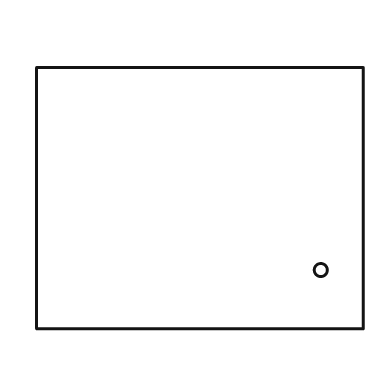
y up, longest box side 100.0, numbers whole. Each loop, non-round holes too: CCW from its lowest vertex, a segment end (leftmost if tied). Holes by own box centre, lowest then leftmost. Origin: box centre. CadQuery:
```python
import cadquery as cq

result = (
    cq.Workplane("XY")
    .moveTo(-50.0, -40.0)
    .lineTo(50.0, -40.0)
    .lineTo(50.0, 40.0)
    .lineTo(-50.0, 40.0)
    .close()
    .moveTo(37.0, -22.0)
    .circle(2.0)
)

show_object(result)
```